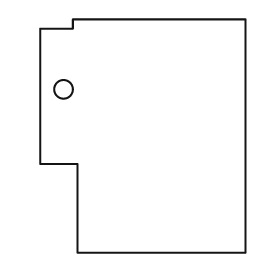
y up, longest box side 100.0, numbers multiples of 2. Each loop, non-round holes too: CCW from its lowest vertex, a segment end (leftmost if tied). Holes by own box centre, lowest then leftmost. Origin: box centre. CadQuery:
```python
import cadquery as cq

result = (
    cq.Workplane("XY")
    .moveTo(-28.0, -50.0)
    .lineTo(44.0, -50.0)
    .lineTo(44.0, 50.0)
    .lineTo(-30.0, 50.0)
    .lineTo(-30.0, 46.0)
    .lineTo(-44.0, 46.0)
    .lineTo(-44.0, -12.0)
    .lineTo(-28.0, -12.0)
    .close()
    .moveTo(-34.0, 20.0)
    .circle(4.0)
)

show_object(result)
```